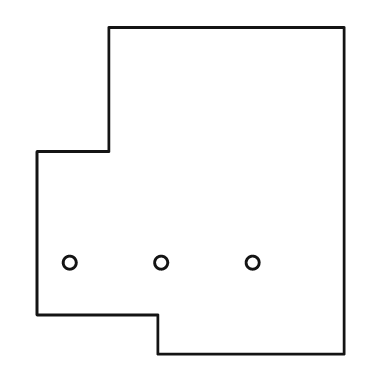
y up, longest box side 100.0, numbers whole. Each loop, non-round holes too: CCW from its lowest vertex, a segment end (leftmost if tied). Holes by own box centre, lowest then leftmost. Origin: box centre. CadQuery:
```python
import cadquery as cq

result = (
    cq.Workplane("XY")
    .moveTo(-10.0, -50.0)
    .lineTo(47.0, -50.0)
    .lineTo(47.0, 50.0)
    .lineTo(-25.0, 50.0)
    .lineTo(-25.0, 12.0)
    .lineTo(-47.0, 12.0)
    .lineTo(-47.0, -38.0)
    .lineTo(-10.0, -38.0)
    .close()
    .moveTo(-37.0, -22.0)
    .circle(2.0)
    .moveTo(-9.0, -22.0)
    .circle(2.0)
    .moveTo(19.0, -22.0)
    .circle(2.0)
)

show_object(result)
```